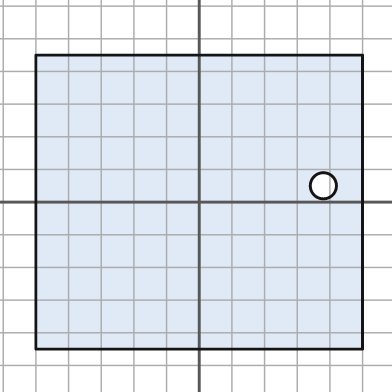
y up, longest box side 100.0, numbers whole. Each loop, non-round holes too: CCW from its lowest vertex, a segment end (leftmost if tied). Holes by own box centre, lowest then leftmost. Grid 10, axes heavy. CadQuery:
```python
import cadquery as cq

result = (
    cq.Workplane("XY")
    .moveTo(-50.0, -45.0)
    .lineTo(50.0, -45.0)
    .lineTo(50.0, 45.0)
    .lineTo(-50.0, 45.0)
    .close()
    .moveTo(38.0, 5.0)
    .circle(4.0)
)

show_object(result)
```